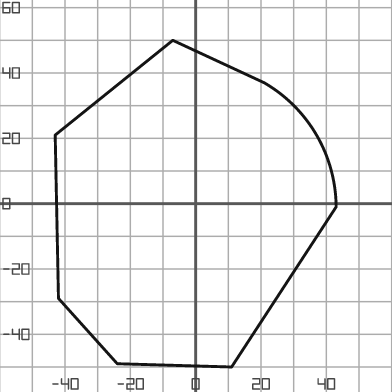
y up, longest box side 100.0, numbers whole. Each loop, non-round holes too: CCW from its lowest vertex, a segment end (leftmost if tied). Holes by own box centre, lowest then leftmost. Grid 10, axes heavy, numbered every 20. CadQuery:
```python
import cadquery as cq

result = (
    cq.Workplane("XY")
    .moveTo(11.0, -50.0)
    .lineTo(43.0, -1.0)
    .threePointArc((37.0, 21.0), (21.0, 37.0))
    .lineTo(-7.0, 50.0)
    .lineTo(-43.0, 21.0)
    .lineTo(-42.0, -29.0)
    .lineTo(-24.0, -49.0)
    .close()
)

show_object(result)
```